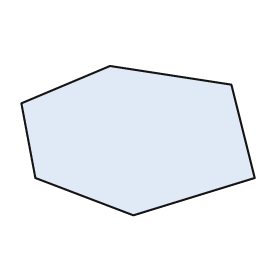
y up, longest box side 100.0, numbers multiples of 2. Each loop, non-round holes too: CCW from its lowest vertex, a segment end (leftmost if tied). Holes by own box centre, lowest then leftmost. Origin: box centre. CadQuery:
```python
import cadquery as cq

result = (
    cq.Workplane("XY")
    .moveTo(-2.0, -32.0)
    .lineTo(50.0, -16.0)
    .lineTo(40.0, 24.0)
    .lineTo(-12.0, 32.0)
    .lineTo(-50.0, 16.0)
    .lineTo(-44.0, -16.0)
    .close()
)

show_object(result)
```